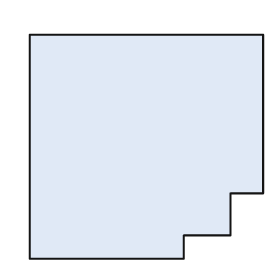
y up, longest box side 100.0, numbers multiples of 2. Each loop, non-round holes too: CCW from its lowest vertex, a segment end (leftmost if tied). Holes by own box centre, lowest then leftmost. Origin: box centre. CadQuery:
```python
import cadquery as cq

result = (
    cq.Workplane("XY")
    .moveTo(-50.0, -48.0)
    .lineTo(16.0, -48.0)
    .lineTo(16.0, -38.0)
    .lineTo(36.0, -38.0)
    .lineTo(36.0, -20.0)
    .lineTo(50.0, -20.0)
    .lineTo(50.0, 48.0)
    .lineTo(-50.0, 48.0)
    .close()
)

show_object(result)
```